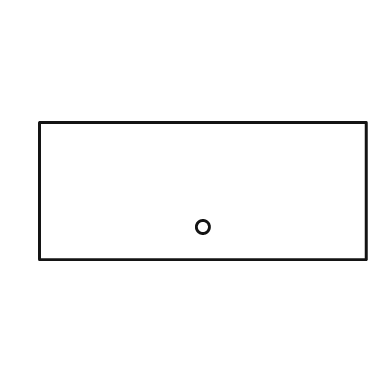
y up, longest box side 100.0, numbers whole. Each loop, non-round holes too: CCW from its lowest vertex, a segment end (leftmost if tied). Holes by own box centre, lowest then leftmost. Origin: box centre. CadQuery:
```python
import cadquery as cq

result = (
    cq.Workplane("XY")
    .moveTo(-50.0, -21.0)
    .lineTo(50.0, -21.0)
    .lineTo(50.0, 21.0)
    .lineTo(-50.0, 21.0)
    .close()
    .moveTo(0.0, -11.0)
    .circle(2.0)
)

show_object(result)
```